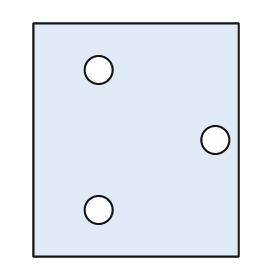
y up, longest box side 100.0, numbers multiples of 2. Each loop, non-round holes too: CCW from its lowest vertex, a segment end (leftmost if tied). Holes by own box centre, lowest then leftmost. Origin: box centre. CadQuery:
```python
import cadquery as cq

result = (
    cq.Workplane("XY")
    .moveTo(-44.0, -50.0)
    .lineTo(44.0, -50.0)
    .lineTo(44.0, 50.0)
    .lineTo(-44.0, 50.0)
    .close()
    .moveTo(-16.0, -30.0)
    .circle(6.0)
    .moveTo(34.0, 0.0)
    .circle(6.0)
    .moveTo(-16.0, 30.0)
    .circle(6.0)
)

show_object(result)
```